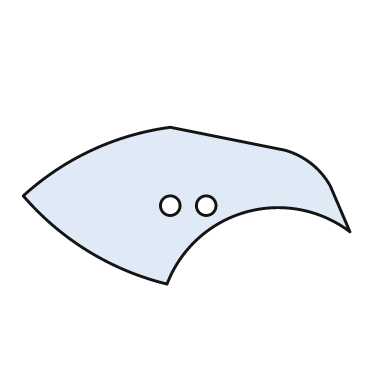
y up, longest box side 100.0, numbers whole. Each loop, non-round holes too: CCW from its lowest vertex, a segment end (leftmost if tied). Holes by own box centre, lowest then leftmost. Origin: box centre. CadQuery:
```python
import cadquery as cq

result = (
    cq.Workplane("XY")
    .moveTo(-6.0, -24.0)
    .threePointArc((18.0, -2.0), (50.0, -8.0))
    .lineTo(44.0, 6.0)
    .threePointArc((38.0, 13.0), (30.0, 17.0))
    .lineTo(-5.0, 24.0)
    .threePointArc((-29.0, 17.0), (-50.0, 3.0))
    .threePointArc((-30.0, -14.0), (-6.0, -24.0))
    .close()
    .moveTo(-5.0, 0.0)
    .circle(3.0)
    .moveTo(6.0, 0.0)
    .circle(3.0)
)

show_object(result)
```